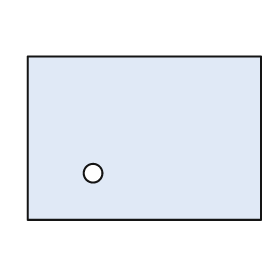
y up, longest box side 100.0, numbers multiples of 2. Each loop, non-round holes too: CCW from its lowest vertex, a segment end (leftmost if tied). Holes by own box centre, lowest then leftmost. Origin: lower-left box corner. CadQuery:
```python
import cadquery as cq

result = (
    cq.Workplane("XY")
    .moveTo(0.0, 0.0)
    .lineTo(100.0, 0.0)
    .lineTo(100.0, 70.0)
    .lineTo(0.0, 70.0)
    .close()
    .moveTo(28.0, 20.0)
    .circle(4.0)
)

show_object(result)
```